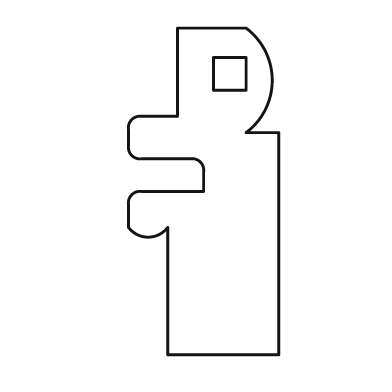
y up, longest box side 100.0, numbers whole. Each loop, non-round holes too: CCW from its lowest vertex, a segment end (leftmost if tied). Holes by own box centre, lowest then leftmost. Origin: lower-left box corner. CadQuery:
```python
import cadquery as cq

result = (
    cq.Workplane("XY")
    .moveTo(12.0, 0.0)
    .lineTo(46.0, 0.0)
    .lineTo(46.0, 68.0)
    .lineTo(36.0, 68.0)
    .threePointArc((44.0, 84.0), (36.0, 100.0))
    .lineTo(15.0, 100.0)
    .lineTo(15.0, 73.0)
    .lineTo(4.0, 73.0)
    .threePointArc((1.0, 72.0), (0.0, 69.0))
    .lineTo(0.0, 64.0)
    .threePointArc((1.0, 61.0), (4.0, 60.0))
    .lineTo(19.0, 60.0)
    .threePointArc((22.0, 59.0), (23.0, 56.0))
    .lineTo(23.0, 50.0)
    .lineTo(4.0, 50.0)
    .threePointArc((1.0, 49.0), (0.0, 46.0))
    .lineTo(0.0, 39.0)
    .threePointArc((6.0, 36.0), (12.0, 39.0))
    .close()
    .moveTo(26.0, 81.0)
    .lineTo(36.0, 81.0)
    .lineTo(36.0, 91.0)
    .lineTo(26.0, 91.0)
    .close()
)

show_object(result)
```